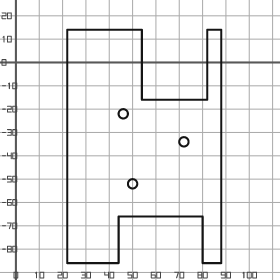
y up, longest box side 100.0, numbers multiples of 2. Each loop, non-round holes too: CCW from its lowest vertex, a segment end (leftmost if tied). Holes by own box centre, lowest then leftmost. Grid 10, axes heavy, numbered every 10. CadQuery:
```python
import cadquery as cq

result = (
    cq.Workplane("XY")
    .moveTo(22.0, -86.0)
    .lineTo(44.0, -86.0)
    .lineTo(44.0, -66.0)
    .lineTo(80.0, -66.0)
    .lineTo(80.0, -86.0)
    .lineTo(88.0, -86.0)
    .lineTo(88.0, 14.0)
    .lineTo(82.0, 14.0)
    .lineTo(82.0, -16.0)
    .lineTo(54.0, -16.0)
    .lineTo(54.0, 14.0)
    .lineTo(22.0, 14.0)
    .close()
    .moveTo(50.0, -52.0)
    .circle(2.0)
    .moveTo(72.0, -34.0)
    .circle(2.0)
    .moveTo(46.0, -22.0)
    .circle(2.0)
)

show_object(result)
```